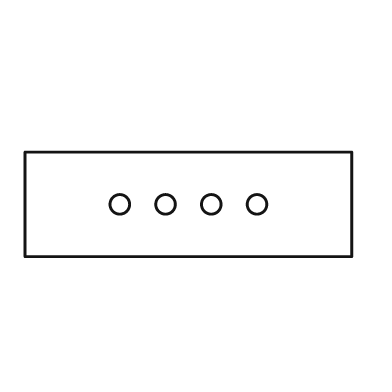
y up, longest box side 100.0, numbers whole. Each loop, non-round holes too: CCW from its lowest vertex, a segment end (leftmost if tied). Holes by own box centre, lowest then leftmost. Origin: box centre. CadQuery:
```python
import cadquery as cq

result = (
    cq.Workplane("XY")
    .moveTo(-50.0, -16.0)
    .lineTo(50.0, -16.0)
    .lineTo(50.0, 16.0)
    .lineTo(-50.0, 16.0)
    .close()
    .moveTo(-21.0, 0.0)
    .circle(3.0)
    .moveTo(-7.0, 0.0)
    .circle(3.0)
    .moveTo(7.0, 0.0)
    .circle(3.0)
    .moveTo(21.0, 0.0)
    .circle(3.0)
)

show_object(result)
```